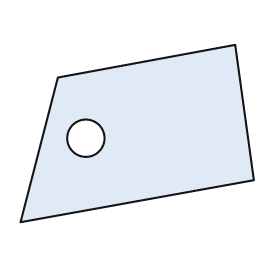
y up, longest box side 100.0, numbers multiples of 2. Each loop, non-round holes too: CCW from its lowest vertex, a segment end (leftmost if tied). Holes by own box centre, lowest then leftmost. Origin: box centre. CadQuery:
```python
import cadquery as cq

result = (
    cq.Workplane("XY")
    .moveTo(-50.0, -38.0)
    .lineTo(50.0, -20.0)
    .lineTo(42.0, 38.0)
    .lineTo(-34.0, 24.0)
    .close()
    .moveTo(-22.0, -2.0)
    .circle(8.0)
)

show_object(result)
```